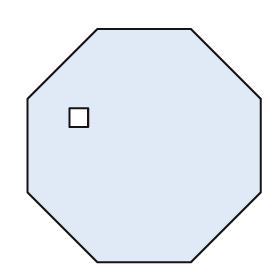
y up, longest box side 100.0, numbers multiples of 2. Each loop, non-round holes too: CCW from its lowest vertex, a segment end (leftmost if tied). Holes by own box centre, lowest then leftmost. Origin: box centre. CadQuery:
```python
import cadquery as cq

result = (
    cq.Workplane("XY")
    .moveTo(-20.0, -50.0)
    .lineTo(20.0, -50.0)
    .lineTo(50.0, -20.0)
    .lineTo(50.0, 20.0)
    .lineTo(20.0, 50.0)
    .lineTo(-20.0, 50.0)
    .lineTo(-50.0, 20.0)
    .lineTo(-50.0, -20.0)
    .close()
    .moveTo(-32.0, 8.0)
    .lineTo(-24.0, 8.0)
    .lineTo(-24.0, 16.0)
    .lineTo(-32.0, 16.0)
    .close()
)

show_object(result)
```